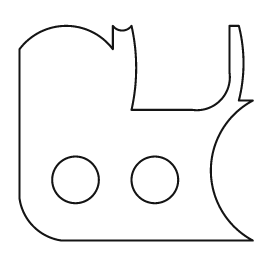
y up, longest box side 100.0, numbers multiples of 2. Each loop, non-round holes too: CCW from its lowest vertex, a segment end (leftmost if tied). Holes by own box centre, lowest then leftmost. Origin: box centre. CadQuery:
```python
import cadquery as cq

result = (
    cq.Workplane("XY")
    .moveTo(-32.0, -46.0)
    .lineTo(50.0, -46.0)
    .threePointArc((32.0, -16.0), (50.0, 14.0))
    .lineTo(44.0, 14.0)
    .threePointArc((46.0, 30.0), (44.0, 46.0))
    .lineTo(40.0, 46.0)
    .lineTo(40.0, 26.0)
    .threePointArc((36.0, 14.0), (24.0, 10.0))
    .lineTo(-2.0, 10.0)
    .threePointArc((0.0, 28.0), (-2.0, 46.0))
    .threePointArc((-6.0, 44.0), (-10.0, 46.0))
    .lineTo(-10.0, 36.0)
    .threePointArc((-30.0, 46.0), (-50.0, 36.0))
    .lineTo(-50.0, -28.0)
    .threePointArc((-44.0, -40.0), (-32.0, -46.0))
    .close()
    .moveTo(-26.0, -20.0)
    .circle(10.0)
    .moveTo(8.0, -20.0)
    .circle(10.0)
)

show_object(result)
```